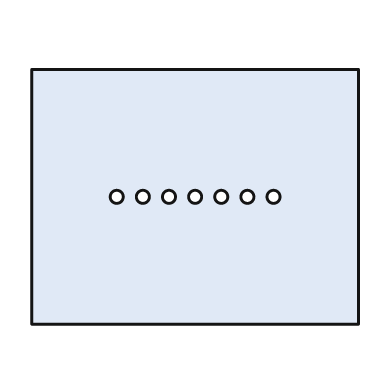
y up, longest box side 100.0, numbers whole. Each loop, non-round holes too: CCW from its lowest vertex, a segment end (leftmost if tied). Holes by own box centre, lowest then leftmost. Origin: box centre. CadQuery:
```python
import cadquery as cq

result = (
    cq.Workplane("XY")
    .moveTo(-50.0, -39.0)
    .lineTo(50.0, -39.0)
    .lineTo(50.0, 39.0)
    .lineTo(-50.0, 39.0)
    .close()
    .moveTo(-24.0, 0.0)
    .circle(2.0)
    .moveTo(-16.0, 0.0)
    .circle(2.0)
    .moveTo(-8.0, 0.0)
    .circle(2.0)
    .moveTo(0.0, 0.0)
    .circle(2.0)
    .moveTo(8.0, 0.0)
    .circle(2.0)
    .moveTo(16.0, 0.0)
    .circle(2.0)
    .moveTo(24.0, 0.0)
    .circle(2.0)
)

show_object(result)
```